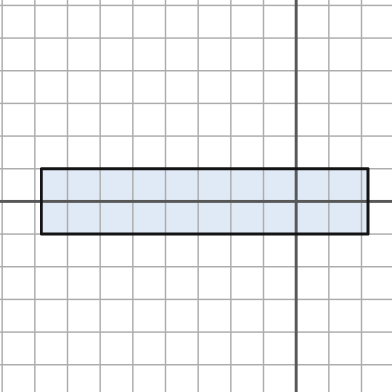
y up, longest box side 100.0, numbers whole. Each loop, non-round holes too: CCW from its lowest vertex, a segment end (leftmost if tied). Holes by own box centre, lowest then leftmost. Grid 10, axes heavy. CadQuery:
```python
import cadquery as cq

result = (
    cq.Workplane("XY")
    .moveTo(-78.0, -10.0)
    .lineTo(22.0, -10.0)
    .lineTo(22.0, 10.0)
    .lineTo(-78.0, 10.0)
    .close()
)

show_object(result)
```